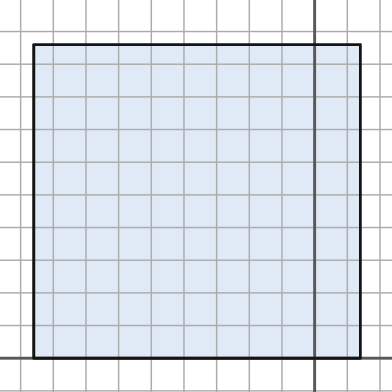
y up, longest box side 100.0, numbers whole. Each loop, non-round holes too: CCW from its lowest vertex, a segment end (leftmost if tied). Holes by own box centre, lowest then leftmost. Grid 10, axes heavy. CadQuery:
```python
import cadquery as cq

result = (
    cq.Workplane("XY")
    .moveTo(-86.0, 0.0)
    .lineTo(14.0, 0.0)
    .lineTo(14.0, 96.0)
    .lineTo(-86.0, 96.0)
    .close()
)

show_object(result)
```